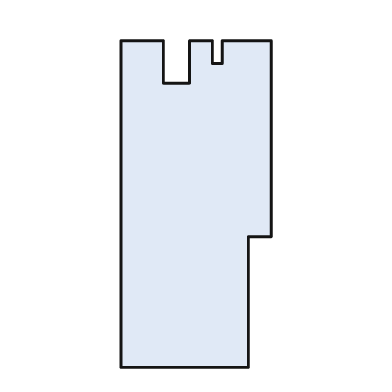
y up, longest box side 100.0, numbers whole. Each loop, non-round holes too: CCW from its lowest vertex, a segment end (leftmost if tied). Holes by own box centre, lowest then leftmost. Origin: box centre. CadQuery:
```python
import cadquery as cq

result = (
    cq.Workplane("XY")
    .moveTo(-23.0, -50.0)
    .lineTo(16.0, -50.0)
    .lineTo(16.0, -10.0)
    .lineTo(23.0, -10.0)
    .lineTo(23.0, 50.0)
    .lineTo(8.0, 50.0)
    .lineTo(8.0, 43.0)
    .lineTo(5.0, 43.0)
    .lineTo(5.0, 50.0)
    .lineTo(-2.0, 50.0)
    .lineTo(-2.0, 37.0)
    .lineTo(-10.0, 37.0)
    .lineTo(-10.0, 50.0)
    .lineTo(-23.0, 50.0)
    .close()
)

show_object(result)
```